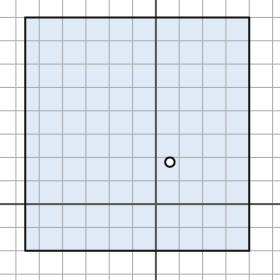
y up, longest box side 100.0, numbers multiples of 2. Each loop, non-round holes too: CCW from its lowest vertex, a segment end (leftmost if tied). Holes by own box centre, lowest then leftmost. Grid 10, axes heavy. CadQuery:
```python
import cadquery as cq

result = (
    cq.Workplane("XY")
    .moveTo(-56.0, -20.0)
    .lineTo(40.0, -20.0)
    .lineTo(40.0, 80.0)
    .lineTo(-56.0, 80.0)
    .close()
    .moveTo(6.0, 18.0)
    .circle(2.0)
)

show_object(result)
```